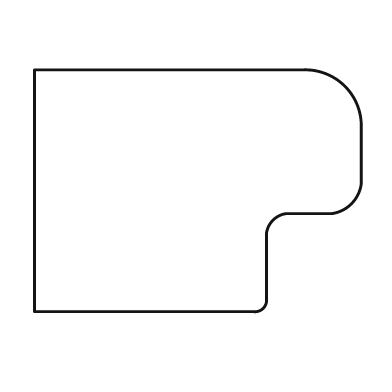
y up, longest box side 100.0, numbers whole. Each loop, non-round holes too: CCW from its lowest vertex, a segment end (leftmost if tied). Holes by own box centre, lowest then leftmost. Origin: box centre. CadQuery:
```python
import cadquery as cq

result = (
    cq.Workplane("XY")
    .moveTo(-50.0, -37.0)
    .lineTo(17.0, -37.0)
    .threePointArc((20.0, -36.0), (21.0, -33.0))
    .lineTo(21.0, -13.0)
    .threePointArc((23.0, -9.0), (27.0, -7.0))
    .lineTo(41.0, -7.0)
    .threePointArc((47.0, -4.0), (50.0, 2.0))
    .lineTo(50.0, 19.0)
    .threePointArc((45.0, 32.0), (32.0, 37.0))
    .lineTo(-50.0, 37.0)
    .close()
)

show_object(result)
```